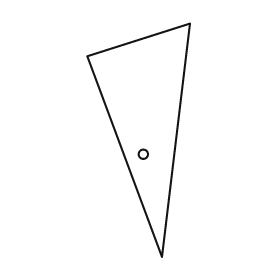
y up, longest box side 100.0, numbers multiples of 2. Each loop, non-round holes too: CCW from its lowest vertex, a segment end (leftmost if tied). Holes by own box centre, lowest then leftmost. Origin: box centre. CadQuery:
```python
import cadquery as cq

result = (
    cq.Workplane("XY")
    .moveTo(10.0, -50.0)
    .lineTo(22.0, 50.0)
    .lineTo(-22.0, 36.0)
    .close()
    .moveTo(2.0, -6.0)
    .circle(2.0)
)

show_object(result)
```